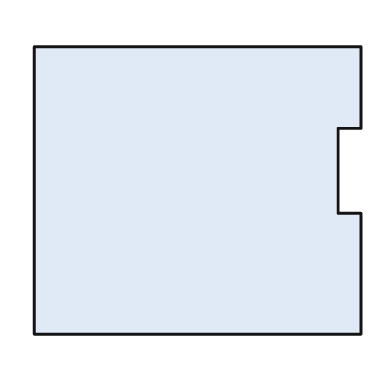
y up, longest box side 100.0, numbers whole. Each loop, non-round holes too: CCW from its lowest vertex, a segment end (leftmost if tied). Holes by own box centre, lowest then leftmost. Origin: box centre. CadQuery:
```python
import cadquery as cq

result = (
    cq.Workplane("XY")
    .moveTo(-50.0, -44.0)
    .lineTo(50.0, -44.0)
    .lineTo(50.0, -7.0)
    .lineTo(43.0, -7.0)
    .lineTo(43.0, 19.0)
    .lineTo(50.0, 19.0)
    .lineTo(50.0, 44.0)
    .lineTo(-50.0, 44.0)
    .close()
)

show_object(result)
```